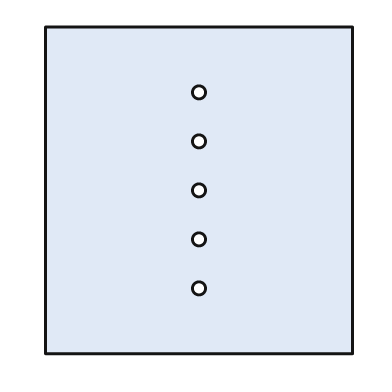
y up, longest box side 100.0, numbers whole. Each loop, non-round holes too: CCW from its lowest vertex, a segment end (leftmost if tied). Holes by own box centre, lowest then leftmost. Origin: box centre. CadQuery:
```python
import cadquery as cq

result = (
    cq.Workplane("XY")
    .moveTo(-47.0, -50.0)
    .lineTo(47.0, -50.0)
    .lineTo(47.0, 50.0)
    .lineTo(-47.0, 50.0)
    .close()
    .moveTo(0.0, -30.0)
    .circle(2.0)
    .moveTo(0.0, -15.0)
    .circle(2.0)
    .moveTo(0.0, 0.0)
    .circle(2.0)
    .moveTo(0.0, 15.0)
    .circle(2.0)
    .moveTo(0.0, 30.0)
    .circle(2.0)
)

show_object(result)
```